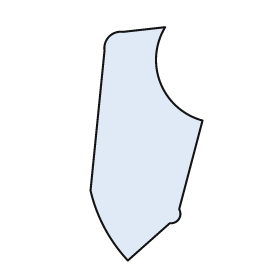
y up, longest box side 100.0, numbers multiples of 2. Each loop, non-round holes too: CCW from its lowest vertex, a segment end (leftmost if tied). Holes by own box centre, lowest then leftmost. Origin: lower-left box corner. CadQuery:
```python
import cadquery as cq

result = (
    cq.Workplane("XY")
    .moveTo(16.0, 0.0)
    .lineTo(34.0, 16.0)
    .threePointArc((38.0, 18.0), (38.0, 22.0))
    .lineTo(48.0, 60.0)
    .threePointArc((30.0, 76.0), (32.0, 100.0))
    .lineTo(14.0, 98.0)
    .threePointArc((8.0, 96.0), (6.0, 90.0))
    .lineTo(0.0, 30.0)
    .threePointArc((6.0, 14.0), (16.0, 0.0))
    .close()
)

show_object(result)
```